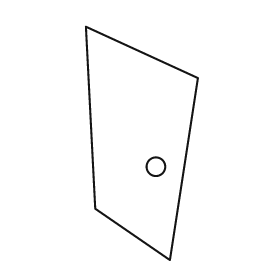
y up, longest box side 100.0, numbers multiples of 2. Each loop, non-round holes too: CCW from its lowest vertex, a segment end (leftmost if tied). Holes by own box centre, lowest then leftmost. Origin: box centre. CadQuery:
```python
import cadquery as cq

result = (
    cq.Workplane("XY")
    .moveTo(12.0, -50.0)
    .lineTo(24.0, 28.0)
    .lineTo(-24.0, 50.0)
    .lineTo(-20.0, -28.0)
    .close()
    .moveTo(6.0, -10.0)
    .circle(4.0)
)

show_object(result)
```